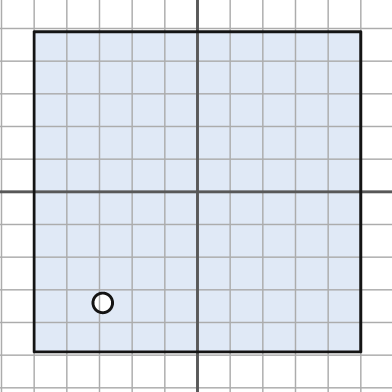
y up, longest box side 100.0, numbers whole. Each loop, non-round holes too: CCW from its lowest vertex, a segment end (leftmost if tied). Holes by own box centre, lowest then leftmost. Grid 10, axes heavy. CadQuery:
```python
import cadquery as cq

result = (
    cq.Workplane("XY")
    .moveTo(-50.0, -49.0)
    .lineTo(50.0, -49.0)
    .lineTo(50.0, 49.0)
    .lineTo(-50.0, 49.0)
    .close()
    .moveTo(-29.0, -34.0)
    .circle(3.0)
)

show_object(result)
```